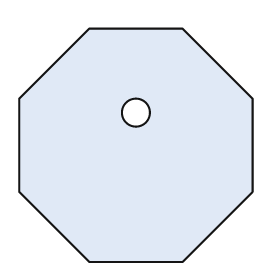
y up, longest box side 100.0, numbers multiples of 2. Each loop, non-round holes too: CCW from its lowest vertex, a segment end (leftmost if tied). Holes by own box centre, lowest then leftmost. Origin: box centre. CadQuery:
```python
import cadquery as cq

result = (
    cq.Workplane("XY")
    .moveTo(-20.0, -50.0)
    .lineTo(20.0, -50.0)
    .lineTo(50.0, -20.0)
    .lineTo(50.0, 20.0)
    .lineTo(20.0, 50.0)
    .lineTo(-20.0, 50.0)
    .lineTo(-50.0, 20.0)
    .lineTo(-50.0, -20.0)
    .close()
    .moveTo(0.0, 14.0)
    .circle(6.0)
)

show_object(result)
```